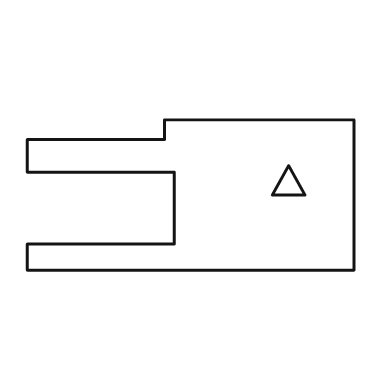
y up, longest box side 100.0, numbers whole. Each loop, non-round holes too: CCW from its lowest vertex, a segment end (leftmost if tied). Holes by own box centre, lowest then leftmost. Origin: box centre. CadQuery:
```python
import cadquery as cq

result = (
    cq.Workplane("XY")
    .moveTo(-50.0, -23.0)
    .lineTo(50.0, -23.0)
    .lineTo(50.0, 23.0)
    .lineTo(-8.0, 23.0)
    .lineTo(-8.0, 17.0)
    .lineTo(-50.0, 17.0)
    .lineTo(-50.0, 7.0)
    .lineTo(-5.0, 7.0)
    .lineTo(-5.0, -15.0)
    .lineTo(-50.0, -15.0)
    .close()
    .moveTo(25.0, 0.0)
    .lineTo(35.0, 0.0)
    .lineTo(30.0, 9.0)
    .close()
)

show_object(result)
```